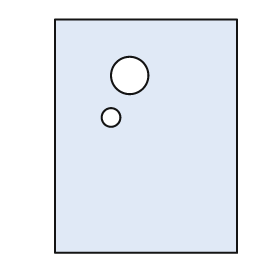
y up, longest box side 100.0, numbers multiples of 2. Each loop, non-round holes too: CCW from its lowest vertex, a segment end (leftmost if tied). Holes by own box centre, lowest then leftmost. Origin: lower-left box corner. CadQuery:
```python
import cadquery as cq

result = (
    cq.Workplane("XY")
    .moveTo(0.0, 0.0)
    .lineTo(78.0, 0.0)
    .lineTo(78.0, 100.0)
    .lineTo(0.0, 100.0)
    .close()
    .moveTo(24.0, 58.0)
    .circle(4.0)
    .moveTo(32.0, 76.0)
    .circle(8.0)
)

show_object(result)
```